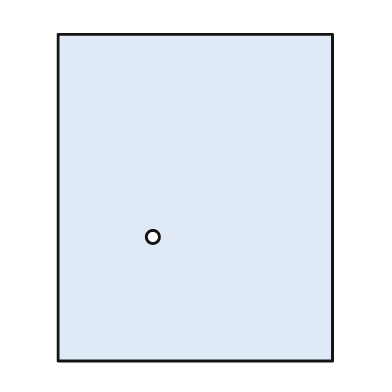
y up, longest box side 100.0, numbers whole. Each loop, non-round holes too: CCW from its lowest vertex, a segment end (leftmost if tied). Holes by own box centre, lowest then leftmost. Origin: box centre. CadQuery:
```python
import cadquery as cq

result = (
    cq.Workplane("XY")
    .moveTo(-42.0, -50.0)
    .lineTo(42.0, -50.0)
    .lineTo(42.0, 50.0)
    .lineTo(-42.0, 50.0)
    .close()
    .moveTo(-13.0, -12.0)
    .circle(2.0)
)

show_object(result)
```